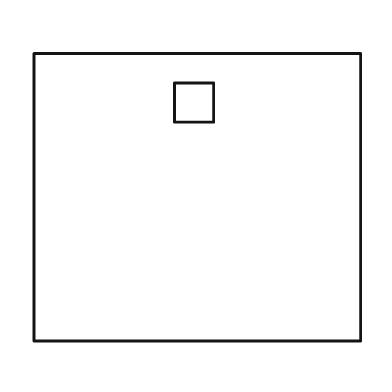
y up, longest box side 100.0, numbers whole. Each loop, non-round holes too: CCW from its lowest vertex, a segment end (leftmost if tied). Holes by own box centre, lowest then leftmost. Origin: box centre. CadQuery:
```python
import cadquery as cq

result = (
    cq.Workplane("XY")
    .moveTo(-50.0, -44.0)
    .lineTo(50.0, -44.0)
    .lineTo(50.0, 44.0)
    .lineTo(-50.0, 44.0)
    .close()
    .moveTo(-7.0, 23.0)
    .lineTo(5.0, 23.0)
    .lineTo(5.0, 35.0)
    .lineTo(-7.0, 35.0)
    .close()
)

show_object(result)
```